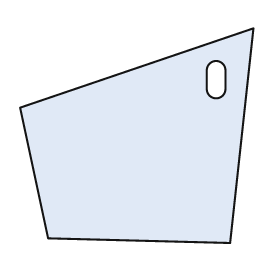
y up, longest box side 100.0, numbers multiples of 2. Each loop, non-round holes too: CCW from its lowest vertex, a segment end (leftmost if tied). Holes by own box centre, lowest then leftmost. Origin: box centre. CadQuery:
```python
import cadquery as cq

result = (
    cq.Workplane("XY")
    .moveTo(40.0, -46.0)
    .lineTo(50.0, 46.0)
    .lineTo(-50.0, 12.0)
    .lineTo(-38.0, -44.0)
    .close()
    .moveTo(30.0, 20.0)
    .threePointArc((34.0, 16.0), (38.0, 20.0))
    .lineTo(38.0, 28.0)
    .threePointArc((34.0, 32.0), (30.0, 28.0))
    .close()
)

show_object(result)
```